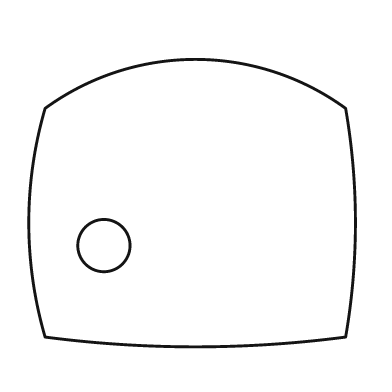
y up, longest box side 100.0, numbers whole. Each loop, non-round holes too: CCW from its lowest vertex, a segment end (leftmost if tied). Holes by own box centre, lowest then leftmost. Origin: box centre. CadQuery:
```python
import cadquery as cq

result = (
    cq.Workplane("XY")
    .moveTo(-45.0, -41.0)
    .threePointArc((1.0, -44.0), (47.0, -41.0))
    .threePointArc((50.0, -6.0), (47.0, 29.0))
    .threePointArc((1.0, 44.0), (-45.0, 29.0))
    .threePointArc((-50.0, -6.0), (-45.0, -41.0))
    .close()
    .moveTo(-27.0, -13.0)
    .circle(8.0)
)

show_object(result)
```